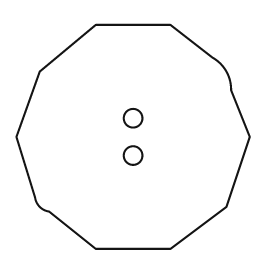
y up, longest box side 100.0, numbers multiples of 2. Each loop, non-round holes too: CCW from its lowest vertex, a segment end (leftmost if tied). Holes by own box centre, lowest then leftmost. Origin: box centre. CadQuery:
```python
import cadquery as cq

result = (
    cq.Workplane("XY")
    .moveTo(-16.0, -48.0)
    .lineTo(16.0, -48.0)
    .lineTo(40.0, -30.0)
    .lineTo(50.0, 0.0)
    .lineTo(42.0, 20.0)
    .threePointArc((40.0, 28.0), (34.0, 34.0))
    .lineTo(16.0, 48.0)
    .lineTo(-16.0, 48.0)
    .lineTo(-40.0, 28.0)
    .lineTo(-50.0, 0.0)
    .lineTo(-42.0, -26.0)
    .threePointArc((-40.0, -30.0), (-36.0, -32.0))
    .close()
    .moveTo(0.0, -8.0)
    .circle(4.0)
    .moveTo(0.0, 8.0)
    .circle(4.0)
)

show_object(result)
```